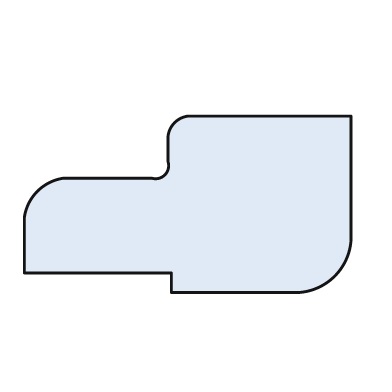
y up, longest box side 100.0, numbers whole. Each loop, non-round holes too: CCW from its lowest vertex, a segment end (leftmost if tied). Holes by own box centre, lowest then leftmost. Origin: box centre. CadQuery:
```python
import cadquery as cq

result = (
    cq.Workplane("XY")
    .moveTo(-5.0, -27.0)
    .lineTo(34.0, -27.0)
    .threePointArc((45.0, -22.0), (50.0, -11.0))
    .lineTo(50.0, 27.0)
    .lineTo(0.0, 27.0)
    .threePointArc((-4.0, 25.0), (-6.0, 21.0))
    .lineTo(-6.0, 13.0)
    .threePointArc((-7.0, 9.0), (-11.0, 8.0))
    .lineTo(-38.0, 8.0)
    .threePointArc((-46.0, 4.0), (-50.0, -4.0))
    .lineTo(-50.0, -21.0)
    .lineTo(-5.0, -21.0)
    .close()
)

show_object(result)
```